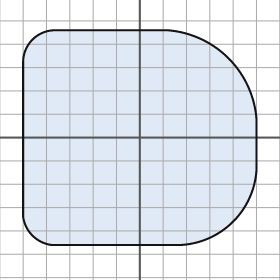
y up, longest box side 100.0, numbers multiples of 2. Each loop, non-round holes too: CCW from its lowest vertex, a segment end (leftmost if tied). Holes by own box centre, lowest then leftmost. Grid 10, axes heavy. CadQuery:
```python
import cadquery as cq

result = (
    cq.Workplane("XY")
    .moveTo(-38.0, -46.0)
    .lineTo(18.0, -46.0)
    .threePointArc((40.0, -36.0), (50.0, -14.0))
    .lineTo(50.0, 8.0)
    .threePointArc((38.0, 34.0), (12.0, 46.0))
    .lineTo(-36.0, 46.0)
    .threePointArc((-46.0, 42.0), (-50.0, 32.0))
    .lineTo(-50.0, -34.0)
    .threePointArc((-46.0, -42.0), (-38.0, -46.0))
    .close()
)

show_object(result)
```